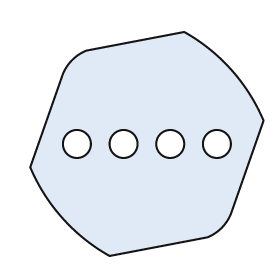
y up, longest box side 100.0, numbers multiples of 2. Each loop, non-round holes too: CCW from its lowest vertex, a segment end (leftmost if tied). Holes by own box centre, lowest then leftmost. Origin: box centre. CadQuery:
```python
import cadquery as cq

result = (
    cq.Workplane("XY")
    .moveTo(-16.0, -48.0)
    .lineTo(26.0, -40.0)
    .threePointArc((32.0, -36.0), (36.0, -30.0))
    .lineTo(50.0, 10.0)
    .threePointArc((36.0, 32.0), (16.0, 48.0))
    .lineTo(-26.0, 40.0)
    .threePointArc((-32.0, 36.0), (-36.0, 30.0))
    .lineTo(-50.0, -10.0)
    .threePointArc((-36.0, -32.0), (-16.0, -48.0))
    .close()
    .moveTo(-30.0, 0.0)
    .circle(6.0)
    .moveTo(-10.0, 0.0)
    .circle(6.0)
    .moveTo(10.0, 0.0)
    .circle(6.0)
    .moveTo(30.0, 0.0)
    .circle(6.0)
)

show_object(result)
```